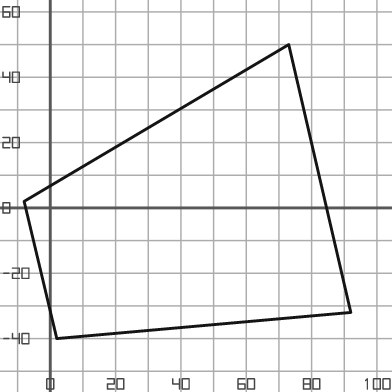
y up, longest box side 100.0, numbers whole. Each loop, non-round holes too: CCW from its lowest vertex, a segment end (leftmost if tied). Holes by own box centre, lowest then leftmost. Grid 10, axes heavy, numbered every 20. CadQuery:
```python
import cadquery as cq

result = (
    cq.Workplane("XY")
    .moveTo(2.0, -40.0)
    .lineTo(92.0, -32.0)
    .lineTo(73.0, 50.0)
    .lineTo(-8.0, 2.0)
    .close()
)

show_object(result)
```